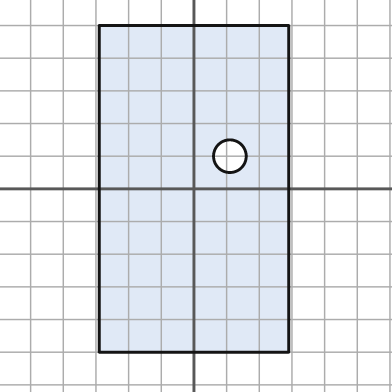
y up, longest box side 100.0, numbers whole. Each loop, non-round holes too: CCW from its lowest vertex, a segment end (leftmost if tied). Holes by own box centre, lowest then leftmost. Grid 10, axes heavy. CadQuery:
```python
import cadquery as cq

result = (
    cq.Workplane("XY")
    .moveTo(-29.0, -50.0)
    .lineTo(29.0, -50.0)
    .lineTo(29.0, 50.0)
    .lineTo(-29.0, 50.0)
    .close()
    .moveTo(11.0, 10.0)
    .circle(5.0)
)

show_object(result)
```